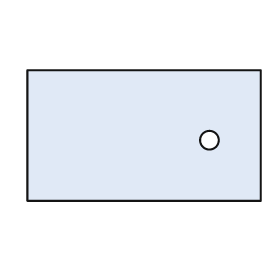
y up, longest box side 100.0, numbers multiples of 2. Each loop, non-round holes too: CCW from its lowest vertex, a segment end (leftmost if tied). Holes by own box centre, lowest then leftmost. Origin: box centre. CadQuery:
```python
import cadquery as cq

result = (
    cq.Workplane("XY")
    .moveTo(-50.0, -28.0)
    .lineTo(50.0, -28.0)
    .lineTo(50.0, 28.0)
    .lineTo(-50.0, 28.0)
    .close()
    .moveTo(28.0, -2.0)
    .circle(4.0)
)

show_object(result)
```